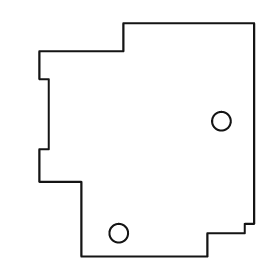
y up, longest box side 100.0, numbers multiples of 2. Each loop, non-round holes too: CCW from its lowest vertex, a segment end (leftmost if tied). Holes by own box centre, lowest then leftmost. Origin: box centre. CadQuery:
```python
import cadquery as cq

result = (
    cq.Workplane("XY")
    .moveTo(-28.0, -50.0)
    .lineTo(26.0, -50.0)
    .lineTo(26.0, -40.0)
    .lineTo(42.0, -40.0)
    .lineTo(42.0, -36.0)
    .lineTo(46.0, -36.0)
    .lineTo(46.0, 50.0)
    .lineTo(-10.0, 50.0)
    .lineTo(-10.0, 38.0)
    .lineTo(-46.0, 38.0)
    .lineTo(-46.0, 26.0)
    .lineTo(-42.0, 26.0)
    .lineTo(-42.0, -4.0)
    .lineTo(-46.0, -4.0)
    .lineTo(-46.0, -18.0)
    .lineTo(-28.0, -18.0)
    .close()
    .moveTo(-12.0, -40.0)
    .circle(4.0)
    .moveTo(32.0, 8.0)
    .circle(4.0)
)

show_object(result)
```